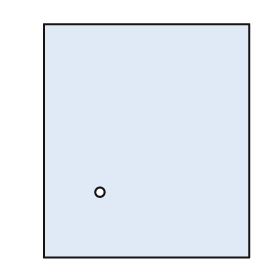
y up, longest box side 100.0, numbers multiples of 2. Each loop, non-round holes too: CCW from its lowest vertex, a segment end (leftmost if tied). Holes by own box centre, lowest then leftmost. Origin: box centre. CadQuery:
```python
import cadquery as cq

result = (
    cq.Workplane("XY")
    .moveTo(-44.0, -50.0)
    .lineTo(44.0, -50.0)
    .lineTo(44.0, 50.0)
    .lineTo(-44.0, 50.0)
    .close()
    .moveTo(-20.0, -22.0)
    .circle(2.0)
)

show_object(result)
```